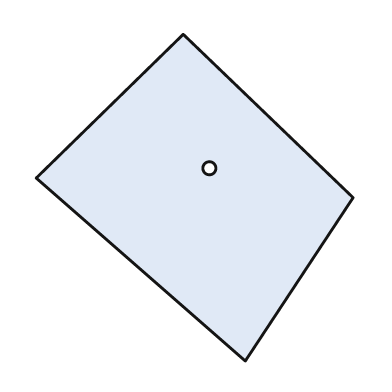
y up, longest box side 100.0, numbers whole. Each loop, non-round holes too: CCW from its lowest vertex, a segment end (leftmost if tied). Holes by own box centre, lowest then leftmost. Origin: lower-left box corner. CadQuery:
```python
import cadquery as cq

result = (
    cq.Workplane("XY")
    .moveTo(64.0, 0.0)
    .lineTo(97.0, 50.0)
    .lineTo(45.0, 100.0)
    .lineTo(0.0, 56.0)
    .close()
    .moveTo(53.0, 59.0)
    .circle(2.0)
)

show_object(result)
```